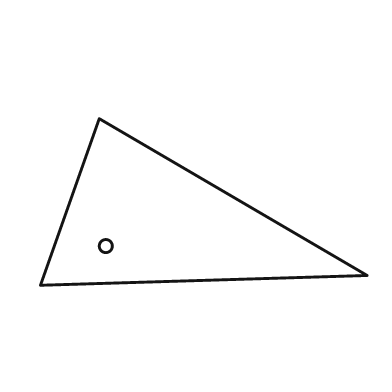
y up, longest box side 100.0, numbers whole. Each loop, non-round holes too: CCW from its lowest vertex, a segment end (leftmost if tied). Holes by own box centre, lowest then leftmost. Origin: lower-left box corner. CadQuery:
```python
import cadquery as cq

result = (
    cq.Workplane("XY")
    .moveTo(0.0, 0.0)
    .lineTo(100.0, 3.0)
    .lineTo(18.0, 51.0)
    .close()
    .moveTo(20.0, 12.0)
    .circle(2.0)
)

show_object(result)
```